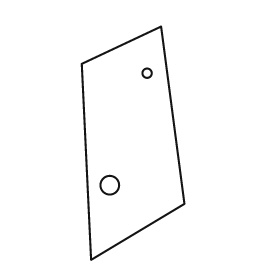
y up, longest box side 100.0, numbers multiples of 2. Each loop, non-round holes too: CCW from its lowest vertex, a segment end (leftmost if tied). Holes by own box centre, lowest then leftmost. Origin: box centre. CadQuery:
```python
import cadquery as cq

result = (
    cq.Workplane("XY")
    .moveTo(-18.0, -50.0)
    .lineTo(22.0, -26.0)
    .lineTo(12.0, 50.0)
    .lineTo(-22.0, 34.0)
    .close()
    .moveTo(-10.0, -18.0)
    .circle(4.0)
    .moveTo(6.0, 30.0)
    .circle(2.0)
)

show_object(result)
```